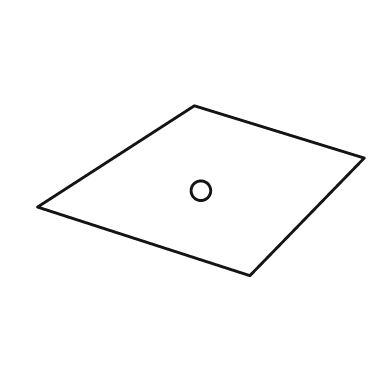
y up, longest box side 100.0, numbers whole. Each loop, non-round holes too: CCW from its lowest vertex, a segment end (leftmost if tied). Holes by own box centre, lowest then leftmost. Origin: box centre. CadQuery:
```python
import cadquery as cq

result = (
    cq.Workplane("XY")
    .moveTo(15.0, -26.0)
    .lineTo(50.0, 10.0)
    .lineTo(-2.0, 26.0)
    .lineTo(-50.0, -5.0)
    .close()
    .moveTo(0.0, 0.0)
    .circle(3.0)
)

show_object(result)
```